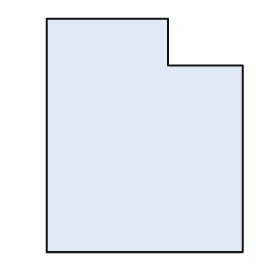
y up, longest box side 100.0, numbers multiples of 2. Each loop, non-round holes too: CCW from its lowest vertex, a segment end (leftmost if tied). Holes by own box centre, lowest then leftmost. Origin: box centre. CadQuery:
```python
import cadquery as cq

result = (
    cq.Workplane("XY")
    .moveTo(-42.0, -50.0)
    .lineTo(42.0, -50.0)
    .lineTo(42.0, 30.0)
    .lineTo(10.0, 30.0)
    .lineTo(10.0, 50.0)
    .lineTo(-42.0, 50.0)
    .close()
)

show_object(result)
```